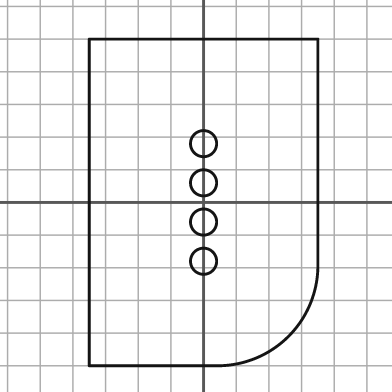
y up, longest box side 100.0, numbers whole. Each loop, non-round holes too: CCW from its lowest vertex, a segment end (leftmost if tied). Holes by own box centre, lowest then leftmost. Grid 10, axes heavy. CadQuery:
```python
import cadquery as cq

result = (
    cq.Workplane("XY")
    .moveTo(-35.0, -50.0)
    .lineTo(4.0, -50.0)
    .threePointArc((26.0, -41.0), (35.0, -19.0))
    .lineTo(35.0, 50.0)
    .lineTo(-35.0, 50.0)
    .close()
    .moveTo(0.0, -18.0)
    .circle(4.0)
    .moveTo(0.0, -6.0)
    .circle(4.0)
    .moveTo(0.0, 6.0)
    .circle(4.0)
    .moveTo(0.0, 18.0)
    .circle(4.0)
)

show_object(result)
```